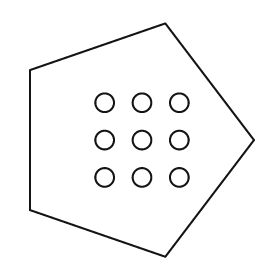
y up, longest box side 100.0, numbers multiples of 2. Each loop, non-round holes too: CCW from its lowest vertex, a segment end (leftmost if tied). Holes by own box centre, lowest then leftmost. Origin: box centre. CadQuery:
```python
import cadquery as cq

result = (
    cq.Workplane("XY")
    .moveTo(10.0, -50.0)
    .lineTo(48.0, 0.0)
    .lineTo(10.0, 50.0)
    .lineTo(-48.0, 30.0)
    .lineTo(-48.0, -30.0)
    .close()
    .moveTo(-16.0, -16.0)
    .circle(4.0)
    .moveTo(0.0, -16.0)
    .circle(4.0)
    .moveTo(16.0, -16.0)
    .circle(4.0)
    .moveTo(-16.0, 0.0)
    .circle(4.0)
    .moveTo(0.0, 0.0)
    .circle(4.0)
    .moveTo(16.0, 0.0)
    .circle(4.0)
    .moveTo(-16.0, 16.0)
    .circle(4.0)
    .moveTo(0.0, 16.0)
    .circle(4.0)
    .moveTo(16.0, 16.0)
    .circle(4.0)
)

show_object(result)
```